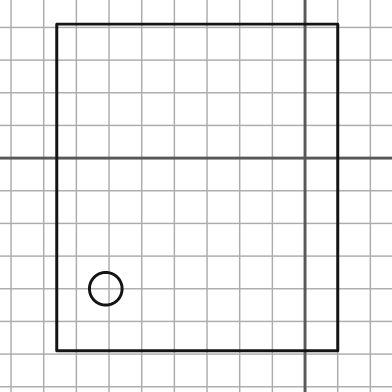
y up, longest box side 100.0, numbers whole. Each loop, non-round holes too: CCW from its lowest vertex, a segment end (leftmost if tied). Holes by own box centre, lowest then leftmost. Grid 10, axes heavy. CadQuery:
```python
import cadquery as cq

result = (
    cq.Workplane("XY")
    .moveTo(-76.0, -59.0)
    .lineTo(10.0, -59.0)
    .lineTo(10.0, 41.0)
    .lineTo(-76.0, 41.0)
    .close()
    .moveTo(-61.0, -40.0)
    .circle(5.0)
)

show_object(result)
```